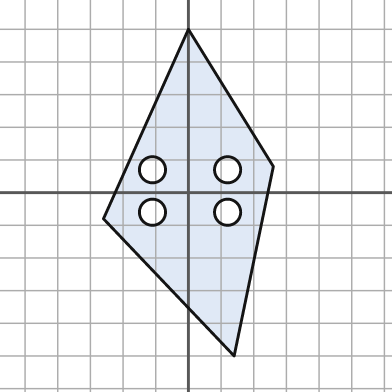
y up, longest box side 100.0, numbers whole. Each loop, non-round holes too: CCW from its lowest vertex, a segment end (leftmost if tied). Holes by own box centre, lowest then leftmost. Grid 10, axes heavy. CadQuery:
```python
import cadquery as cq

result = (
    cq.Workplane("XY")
    .moveTo(14.0, -50.0)
    .lineTo(26.0, 8.0)
    .lineTo(0.0, 50.0)
    .lineTo(-26.0, -8.0)
    .close()
    .moveTo(-11.0, -6.0)
    .circle(4.0)
    .moveTo(12.0, -6.0)
    .circle(4.0)
    .moveTo(-11.0, 7.0)
    .circle(4.0)
    .moveTo(12.0, 7.0)
    .circle(4.0)
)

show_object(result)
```